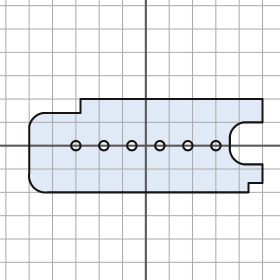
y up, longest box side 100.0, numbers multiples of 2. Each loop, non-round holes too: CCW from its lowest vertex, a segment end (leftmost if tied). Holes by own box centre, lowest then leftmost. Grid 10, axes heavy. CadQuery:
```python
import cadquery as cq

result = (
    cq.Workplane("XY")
    .moveTo(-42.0, -20.0)
    .lineTo(44.0, -20.0)
    .lineTo(44.0, -16.0)
    .lineTo(50.0, -16.0)
    .lineTo(50.0, -8.0)
    .lineTo(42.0, -8.0)
    .threePointArc((38.0, -6.0), (36.0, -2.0))
    .lineTo(36.0, 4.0)
    .threePointArc((38.0, 8.0), (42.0, 10.0))
    .lineTo(50.0, 10.0)
    .lineTo(50.0, 20.0)
    .lineTo(-28.0, 20.0)
    .lineTo(-28.0, 14.0)
    .lineTo(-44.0, 14.0)
    .threePointArc((-48.0, 12.0), (-50.0, 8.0))
    .lineTo(-50.0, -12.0)
    .threePointArc((-48.0, -18.0), (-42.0, -20.0))
    .close()
    .moveTo(-30.0, 0.0)
    .circle(2.0)
    .moveTo(-18.0, 0.0)
    .circle(2.0)
    .moveTo(-6.0, 0.0)
    .circle(2.0)
    .moveTo(6.0, 0.0)
    .circle(2.0)
    .moveTo(18.0, 0.0)
    .circle(2.0)
    .moveTo(30.0, 0.0)
    .circle(2.0)
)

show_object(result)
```